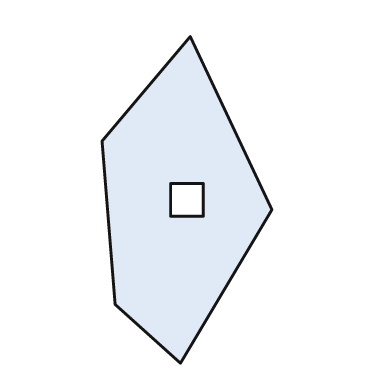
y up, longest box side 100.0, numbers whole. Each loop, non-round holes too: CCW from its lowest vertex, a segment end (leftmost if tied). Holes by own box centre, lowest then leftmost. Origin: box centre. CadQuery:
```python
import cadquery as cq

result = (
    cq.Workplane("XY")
    .moveTo(-2.0, -50.0)
    .lineTo(26.0, -3.0)
    .lineTo(1.0, 50.0)
    .lineTo(-26.0, 18.0)
    .lineTo(-22.0, -32.0)
    .close()
    .moveTo(-5.0, -5.0)
    .lineTo(5.0, -5.0)
    .lineTo(5.0, 5.0)
    .lineTo(-5.0, 5.0)
    .close()
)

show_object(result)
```